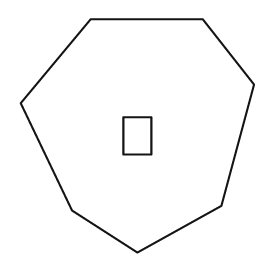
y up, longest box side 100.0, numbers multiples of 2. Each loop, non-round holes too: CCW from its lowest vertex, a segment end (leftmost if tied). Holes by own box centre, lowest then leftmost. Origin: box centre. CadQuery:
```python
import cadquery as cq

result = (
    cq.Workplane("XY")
    .moveTo(0.0, -50.0)
    .lineTo(36.0, -30.0)
    .lineTo(50.0, 22.0)
    .lineTo(28.0, 50.0)
    .lineTo(-20.0, 50.0)
    .lineTo(-50.0, 14.0)
    .lineTo(-28.0, -32.0)
    .close()
    .moveTo(-6.0, -8.0)
    .lineTo(6.0, -8.0)
    .lineTo(6.0, 8.0)
    .lineTo(-6.0, 8.0)
    .close()
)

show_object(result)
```